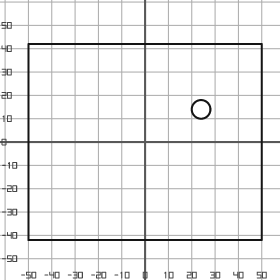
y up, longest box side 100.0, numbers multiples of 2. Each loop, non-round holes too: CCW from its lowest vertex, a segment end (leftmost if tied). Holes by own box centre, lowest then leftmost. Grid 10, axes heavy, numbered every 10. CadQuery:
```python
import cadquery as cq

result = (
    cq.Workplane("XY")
    .moveTo(-50.0, -42.0)
    .lineTo(50.0, -42.0)
    .lineTo(50.0, 42.0)
    .lineTo(-50.0, 42.0)
    .close()
    .moveTo(24.0, 14.0)
    .circle(4.0)
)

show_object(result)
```